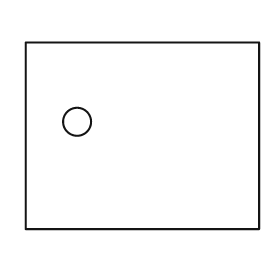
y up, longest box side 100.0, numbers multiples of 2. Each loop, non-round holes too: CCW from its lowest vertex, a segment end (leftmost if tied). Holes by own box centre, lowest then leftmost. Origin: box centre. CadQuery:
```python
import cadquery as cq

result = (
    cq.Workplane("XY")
    .moveTo(-50.0, -40.0)
    .lineTo(50.0, -40.0)
    .lineTo(50.0, 40.0)
    .lineTo(-50.0, 40.0)
    .close()
    .moveTo(-28.0, 6.0)
    .circle(6.0)
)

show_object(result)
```